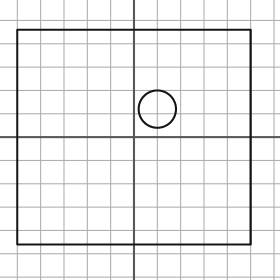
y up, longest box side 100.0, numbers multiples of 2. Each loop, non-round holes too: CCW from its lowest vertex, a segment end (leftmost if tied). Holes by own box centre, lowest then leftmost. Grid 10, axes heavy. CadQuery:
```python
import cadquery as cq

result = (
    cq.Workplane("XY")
    .moveTo(-50.0, -46.0)
    .lineTo(50.0, -46.0)
    .lineTo(50.0, 46.0)
    .lineTo(-50.0, 46.0)
    .close()
    .moveTo(10.0, 12.0)
    .circle(8.0)
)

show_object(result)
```